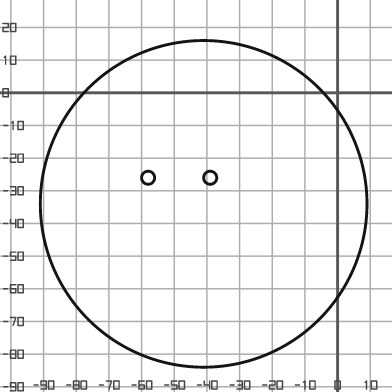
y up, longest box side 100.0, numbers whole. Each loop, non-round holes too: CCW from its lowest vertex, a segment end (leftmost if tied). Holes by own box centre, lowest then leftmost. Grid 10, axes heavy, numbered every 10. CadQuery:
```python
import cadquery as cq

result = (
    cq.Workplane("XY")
    .moveTo(-41.0, -34.0)
    .circle(50.0)
    .moveTo(-58.0, -26.0)
    .circle(2.0)
    .moveTo(-39.0, -26.0)
    .circle(2.0)
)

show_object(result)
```